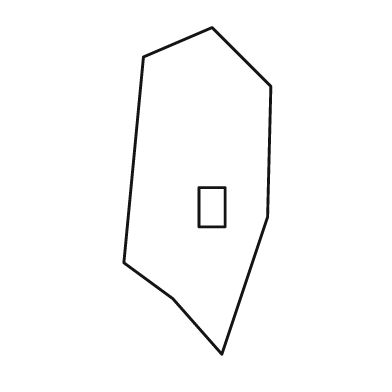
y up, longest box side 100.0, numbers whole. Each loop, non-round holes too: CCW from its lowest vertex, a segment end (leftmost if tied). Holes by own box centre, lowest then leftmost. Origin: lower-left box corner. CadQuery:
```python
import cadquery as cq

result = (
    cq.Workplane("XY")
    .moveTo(30.0, 0.0)
    .lineTo(44.0, 42.0)
    .lineTo(45.0, 82.0)
    .lineTo(27.0, 100.0)
    .lineTo(6.0, 91.0)
    .lineTo(0.0, 28.0)
    .lineTo(15.0, 17.0)
    .close()
    .moveTo(23.0, 39.0)
    .lineTo(31.0, 39.0)
    .lineTo(31.0, 51.0)
    .lineTo(23.0, 51.0)
    .close()
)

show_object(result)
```